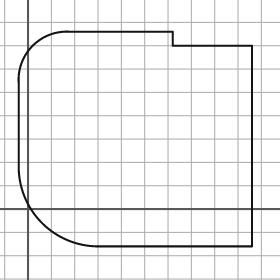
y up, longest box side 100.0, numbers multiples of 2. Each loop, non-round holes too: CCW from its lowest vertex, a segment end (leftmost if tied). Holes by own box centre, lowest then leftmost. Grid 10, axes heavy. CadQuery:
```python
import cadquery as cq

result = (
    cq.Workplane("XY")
    .moveTo(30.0, -16.0)
    .lineTo(96.0, -16.0)
    .lineTo(96.0, 70.0)
    .lineTo(62.0, 70.0)
    .lineTo(62.0, 76.0)
    .lineTo(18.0, 76.0)
    .threePointArc((2.0, 70.0), (-4.0, 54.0))
    .lineTo(-4.0, 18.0)
    .threePointArc((6.0, -6.0), (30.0, -16.0))
    .close()
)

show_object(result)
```